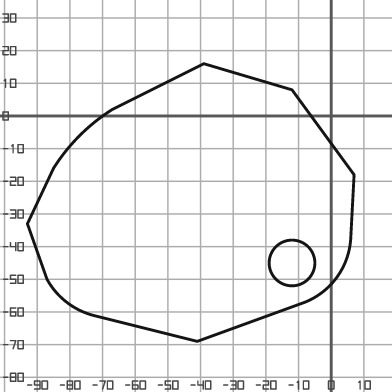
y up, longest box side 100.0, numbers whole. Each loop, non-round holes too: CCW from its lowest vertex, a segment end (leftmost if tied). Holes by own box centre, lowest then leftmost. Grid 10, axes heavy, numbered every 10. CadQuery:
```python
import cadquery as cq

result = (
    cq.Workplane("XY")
    .moveTo(-41.0, -69.0)
    .lineTo(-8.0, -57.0)
    .threePointArc((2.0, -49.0), (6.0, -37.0))
    .lineTo(7.0, -18.0)
    .lineTo(-12.0, 8.0)
    .lineTo(-39.0, 16.0)
    .lineTo(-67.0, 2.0)
    .threePointArc((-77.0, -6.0), (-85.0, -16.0))
    .lineTo(-93.0, -33.0)
    .lineTo(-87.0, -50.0)
    .threePointArc((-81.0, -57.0), (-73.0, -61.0))
    .close()
    .moveTo(-12.0, -45.0)
    .circle(7.0)
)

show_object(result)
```